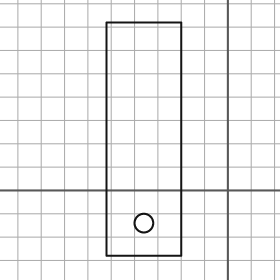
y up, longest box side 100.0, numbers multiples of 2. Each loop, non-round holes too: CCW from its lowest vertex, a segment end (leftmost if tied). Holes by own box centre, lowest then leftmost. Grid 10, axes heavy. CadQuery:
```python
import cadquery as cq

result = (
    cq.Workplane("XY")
    .moveTo(-52.0, -28.0)
    .lineTo(-20.0, -28.0)
    .lineTo(-20.0, 72.0)
    .lineTo(-52.0, 72.0)
    .close()
    .moveTo(-36.0, -14.0)
    .circle(4.0)
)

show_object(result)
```